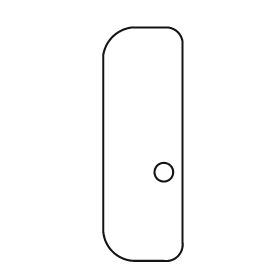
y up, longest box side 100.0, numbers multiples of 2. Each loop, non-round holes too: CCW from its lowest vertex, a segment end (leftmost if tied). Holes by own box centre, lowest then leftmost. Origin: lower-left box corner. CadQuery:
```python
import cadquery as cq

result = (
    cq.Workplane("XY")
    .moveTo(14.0, 0.0)
    .lineTo(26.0, 0.0)
    .threePointArc((32.0, 2.0), (34.0, 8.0))
    .lineTo(34.0, 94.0)
    .threePointArc((32.0, 98.0), (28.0, 100.0))
    .lineTo(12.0, 100.0)
    .threePointArc((4.0, 96.0), (0.0, 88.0))
    .lineTo(0.0, 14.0)
    .threePointArc((4.0, 4.0), (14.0, 0.0))
    .close()
    .moveTo(26.0, 38.0)
    .circle(4.0)
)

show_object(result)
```